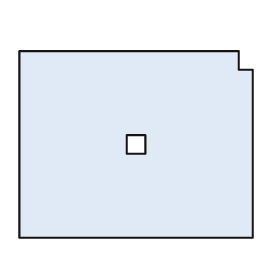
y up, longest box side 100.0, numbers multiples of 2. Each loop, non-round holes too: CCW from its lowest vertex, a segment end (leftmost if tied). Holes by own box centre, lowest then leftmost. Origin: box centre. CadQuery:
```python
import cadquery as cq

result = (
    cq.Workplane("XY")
    .moveTo(-50.0, -40.0)
    .lineTo(50.0, -40.0)
    .lineTo(50.0, 32.0)
    .lineTo(44.0, 32.0)
    .lineTo(44.0, 40.0)
    .lineTo(-50.0, 40.0)
    .close()
    .moveTo(-4.0, -4.0)
    .lineTo(4.0, -4.0)
    .lineTo(4.0, 4.0)
    .lineTo(-4.0, 4.0)
    .close()
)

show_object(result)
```